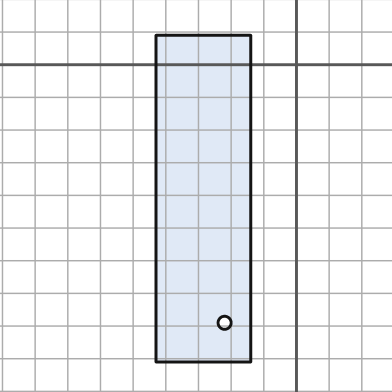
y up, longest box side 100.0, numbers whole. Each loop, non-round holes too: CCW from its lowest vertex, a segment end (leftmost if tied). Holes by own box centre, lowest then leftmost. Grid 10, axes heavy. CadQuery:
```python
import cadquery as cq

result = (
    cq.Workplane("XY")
    .moveTo(-43.0, -91.0)
    .lineTo(-14.0, -91.0)
    .lineTo(-14.0, 9.0)
    .lineTo(-43.0, 9.0)
    .close()
    .moveTo(-22.0, -79.0)
    .circle(2.0)
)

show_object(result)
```